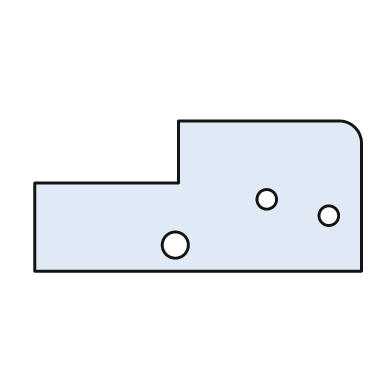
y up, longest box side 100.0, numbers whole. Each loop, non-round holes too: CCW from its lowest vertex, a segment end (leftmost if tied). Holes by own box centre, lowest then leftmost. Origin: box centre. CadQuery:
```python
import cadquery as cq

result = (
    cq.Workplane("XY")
    .moveTo(-50.0, -23.0)
    .lineTo(50.0, -23.0)
    .lineTo(50.0, 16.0)
    .threePointArc((48.0, 21.0), (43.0, 23.0))
    .lineTo(-6.0, 23.0)
    .lineTo(-6.0, 4.0)
    .lineTo(-50.0, 4.0)
    .close()
    .moveTo(-7.0, -15.0)
    .circle(4.0)
    .moveTo(40.0, -6.0)
    .circle(3.0)
    .moveTo(21.0, -1.0)
    .circle(3.0)
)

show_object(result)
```